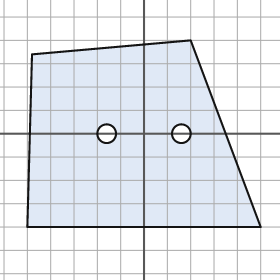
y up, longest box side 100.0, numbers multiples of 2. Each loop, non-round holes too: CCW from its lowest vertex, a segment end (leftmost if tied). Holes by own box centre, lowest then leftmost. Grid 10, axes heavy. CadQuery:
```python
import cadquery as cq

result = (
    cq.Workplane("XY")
    .moveTo(-50.0, -40.0)
    .lineTo(50.0, -40.0)
    .lineTo(20.0, 40.0)
    .lineTo(-48.0, 34.0)
    .close()
    .moveTo(-16.0, 0.0)
    .circle(4.0)
    .moveTo(16.0, 0.0)
    .circle(4.0)
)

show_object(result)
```